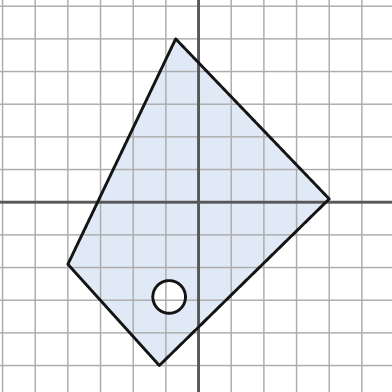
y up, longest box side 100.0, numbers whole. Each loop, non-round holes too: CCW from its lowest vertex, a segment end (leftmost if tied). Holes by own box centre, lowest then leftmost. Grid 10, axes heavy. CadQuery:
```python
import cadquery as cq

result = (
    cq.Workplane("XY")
    .moveTo(-12.0, -50.0)
    .lineTo(40.0, 1.0)
    .lineTo(-7.0, 50.0)
    .lineTo(-40.0, -19.0)
    .close()
    .moveTo(-9.0, -29.0)
    .circle(5.0)
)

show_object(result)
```